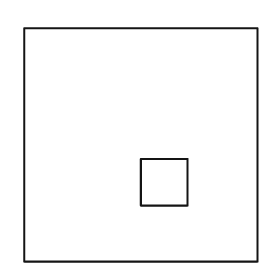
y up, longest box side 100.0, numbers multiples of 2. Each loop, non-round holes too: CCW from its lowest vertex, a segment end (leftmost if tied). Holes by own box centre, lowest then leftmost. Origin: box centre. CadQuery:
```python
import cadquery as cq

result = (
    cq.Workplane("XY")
    .moveTo(-50.0, -50.0)
    .lineTo(50.0, -50.0)
    .lineTo(50.0, 50.0)
    .lineTo(-50.0, 50.0)
    .close()
    .moveTo(0.0, -26.0)
    .lineTo(20.0, -26.0)
    .lineTo(20.0, -6.0)
    .lineTo(0.0, -6.0)
    .close()
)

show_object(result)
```